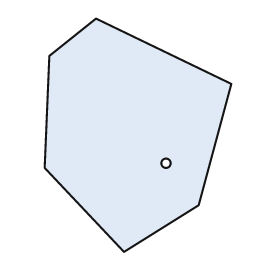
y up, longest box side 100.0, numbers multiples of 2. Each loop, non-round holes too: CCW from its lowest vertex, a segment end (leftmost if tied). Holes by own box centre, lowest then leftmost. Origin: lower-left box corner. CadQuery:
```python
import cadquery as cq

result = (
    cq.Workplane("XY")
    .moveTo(34.0, 0.0)
    .lineTo(66.0, 20.0)
    .lineTo(80.0, 72.0)
    .lineTo(22.0, 100.0)
    .lineTo(2.0, 84.0)
    .lineTo(0.0, 36.0)
    .close()
    .moveTo(52.0, 38.0)
    .circle(2.0)
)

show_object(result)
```